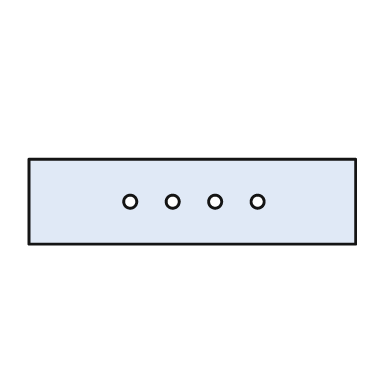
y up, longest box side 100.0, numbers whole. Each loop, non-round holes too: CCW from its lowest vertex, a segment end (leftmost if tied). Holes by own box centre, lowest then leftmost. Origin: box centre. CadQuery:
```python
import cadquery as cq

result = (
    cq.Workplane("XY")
    .moveTo(-50.0, -13.0)
    .lineTo(50.0, -13.0)
    .lineTo(50.0, 13.0)
    .lineTo(-50.0, 13.0)
    .close()
    .moveTo(-19.0, 0.0)
    .circle(2.0)
    .moveTo(-6.0, 0.0)
    .circle(2.0)
    .moveTo(7.0, 0.0)
    .circle(2.0)
    .moveTo(20.0, 0.0)
    .circle(2.0)
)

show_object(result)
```